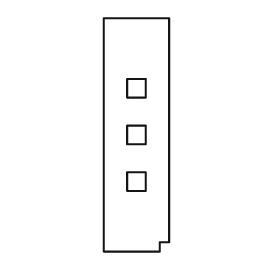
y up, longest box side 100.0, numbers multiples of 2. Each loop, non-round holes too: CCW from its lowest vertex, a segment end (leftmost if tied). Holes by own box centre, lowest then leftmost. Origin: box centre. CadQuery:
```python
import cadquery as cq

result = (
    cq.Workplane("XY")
    .moveTo(-14.0, -50.0)
    .lineTo(10.0, -50.0)
    .lineTo(10.0, -46.0)
    .lineTo(14.0, -46.0)
    .lineTo(14.0, 50.0)
    .lineTo(-14.0, 50.0)
    .close()
    .moveTo(-4.0, -24.0)
    .lineTo(4.0, -24.0)
    .lineTo(4.0, -16.0)
    .lineTo(-4.0, -16.0)
    .close()
    .moveTo(-4.0, -4.0)
    .lineTo(4.0, -4.0)
    .lineTo(4.0, 4.0)
    .lineTo(-4.0, 4.0)
    .close()
    .moveTo(-4.0, 16.0)
    .lineTo(4.0, 16.0)
    .lineTo(4.0, 24.0)
    .lineTo(-4.0, 24.0)
    .close()
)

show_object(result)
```